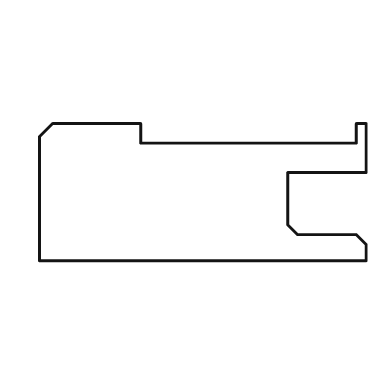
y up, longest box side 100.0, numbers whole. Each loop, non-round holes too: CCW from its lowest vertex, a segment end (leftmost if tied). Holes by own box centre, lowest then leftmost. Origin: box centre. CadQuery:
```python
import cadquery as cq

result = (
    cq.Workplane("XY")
    .moveTo(-50.0, -21.0)
    .lineTo(50.0, -21.0)
    .lineTo(50.0, -16.0)
    .lineTo(47.0, -13.0)
    .lineTo(29.0, -13.0)
    .lineTo(26.0, -10.0)
    .lineTo(26.0, 6.0)
    .lineTo(50.0, 6.0)
    .lineTo(50.0, 21.0)
    .lineTo(47.0, 21.0)
    .lineTo(47.0, 15.0)
    .lineTo(-19.0, 15.0)
    .lineTo(-19.0, 21.0)
    .lineTo(-46.0, 21.0)
    .lineTo(-50.0, 17.0)
    .close()
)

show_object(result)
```